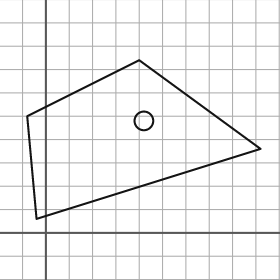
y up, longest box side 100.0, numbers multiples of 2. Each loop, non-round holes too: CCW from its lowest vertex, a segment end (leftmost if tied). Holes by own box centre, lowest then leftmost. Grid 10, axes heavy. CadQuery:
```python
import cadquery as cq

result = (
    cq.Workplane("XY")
    .moveTo(-4.0, 6.0)
    .lineTo(92.0, 36.0)
    .lineTo(40.0, 74.0)
    .lineTo(-8.0, 50.0)
    .close()
    .moveTo(42.0, 48.0)
    .circle(4.0)
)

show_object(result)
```